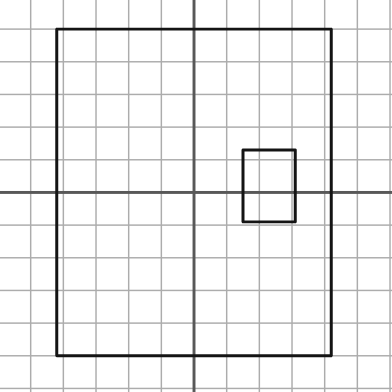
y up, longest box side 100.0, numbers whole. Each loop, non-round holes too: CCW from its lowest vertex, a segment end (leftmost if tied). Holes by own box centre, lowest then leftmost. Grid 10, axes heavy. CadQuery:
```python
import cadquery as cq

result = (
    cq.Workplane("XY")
    .moveTo(-42.0, -50.0)
    .lineTo(42.0, -50.0)
    .lineTo(42.0, 50.0)
    .lineTo(-42.0, 50.0)
    .close()
    .moveTo(15.0, -9.0)
    .lineTo(31.0, -9.0)
    .lineTo(31.0, 13.0)
    .lineTo(15.0, 13.0)
    .close()
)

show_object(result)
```